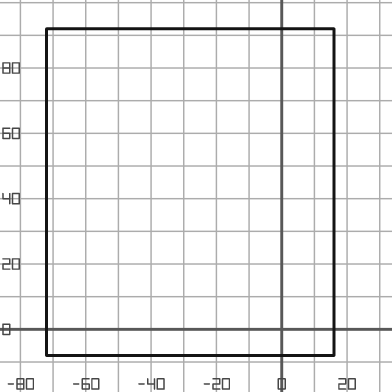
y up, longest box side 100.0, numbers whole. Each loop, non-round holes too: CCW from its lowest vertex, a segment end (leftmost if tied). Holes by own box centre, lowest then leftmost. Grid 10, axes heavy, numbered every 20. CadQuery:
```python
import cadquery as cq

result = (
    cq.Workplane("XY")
    .moveTo(-72.0, -8.0)
    .lineTo(16.0, -8.0)
    .lineTo(16.0, 92.0)
    .lineTo(-72.0, 92.0)
    .close()
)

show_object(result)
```